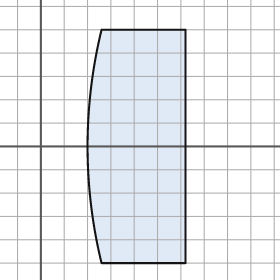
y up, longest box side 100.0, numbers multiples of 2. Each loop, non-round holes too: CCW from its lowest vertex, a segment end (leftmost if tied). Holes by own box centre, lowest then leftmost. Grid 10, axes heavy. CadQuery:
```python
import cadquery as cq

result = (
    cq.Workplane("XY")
    .moveTo(26.0, -50.0)
    .lineTo(62.0, -50.0)
    .lineTo(62.0, 50.0)
    .lineTo(26.0, 50.0)
    .threePointArc((20.0, 0.0), (26.0, -50.0))
    .close()
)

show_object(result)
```